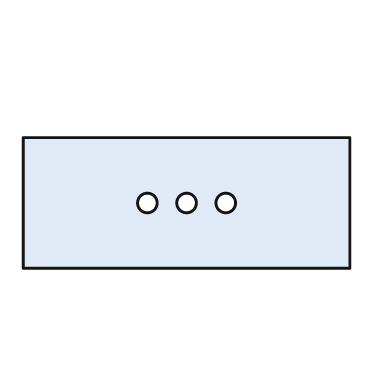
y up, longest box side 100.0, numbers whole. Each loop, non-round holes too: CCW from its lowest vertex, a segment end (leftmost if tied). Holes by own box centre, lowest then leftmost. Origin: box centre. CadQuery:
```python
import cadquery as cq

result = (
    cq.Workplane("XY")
    .moveTo(-50.0, -20.0)
    .lineTo(50.0, -20.0)
    .lineTo(50.0, 20.0)
    .lineTo(-50.0, 20.0)
    .close()
    .moveTo(-12.0, 0.0)
    .circle(3.0)
    .moveTo(0.0, 0.0)
    .circle(3.0)
    .moveTo(12.0, 0.0)
    .circle(3.0)
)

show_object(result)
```